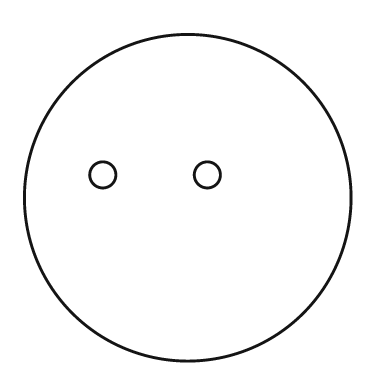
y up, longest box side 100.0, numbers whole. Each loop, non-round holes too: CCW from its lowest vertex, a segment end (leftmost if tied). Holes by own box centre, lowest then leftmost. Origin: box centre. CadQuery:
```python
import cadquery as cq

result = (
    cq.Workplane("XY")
    .moveTo(0.0, 0.0)
    .circle(50.0)
    .moveTo(-26.0, 7.0)
    .circle(4.0)
    .moveTo(6.0, 7.0)
    .circle(4.0)
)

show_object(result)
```